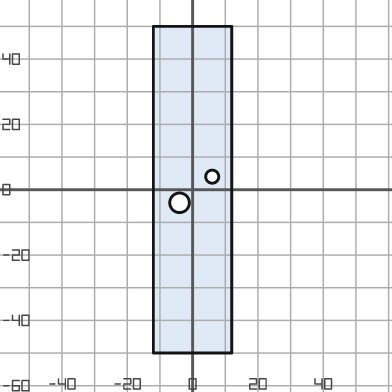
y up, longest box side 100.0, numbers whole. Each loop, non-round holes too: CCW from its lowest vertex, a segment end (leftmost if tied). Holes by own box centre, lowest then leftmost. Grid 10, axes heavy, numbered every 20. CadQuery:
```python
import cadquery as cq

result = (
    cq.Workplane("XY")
    .moveTo(-12.0, -50.0)
    .lineTo(12.0, -50.0)
    .lineTo(12.0, 50.0)
    .lineTo(-12.0, 50.0)
    .close()
    .moveTo(-4.0, -4.0)
    .circle(3.0)
    .moveTo(6.0, 4.0)
    .circle(2.0)
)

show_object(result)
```